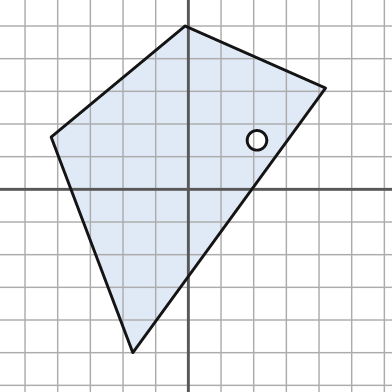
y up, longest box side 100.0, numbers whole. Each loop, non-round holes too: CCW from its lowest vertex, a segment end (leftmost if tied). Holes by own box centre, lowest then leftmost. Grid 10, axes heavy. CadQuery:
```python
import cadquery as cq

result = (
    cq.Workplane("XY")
    .moveTo(-17.0, -50.0)
    .lineTo(42.0, 31.0)
    .lineTo(-1.0, 50.0)
    .lineTo(-42.0, 16.0)
    .close()
    .moveTo(21.0, 15.0)
    .circle(3.0)
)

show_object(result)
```